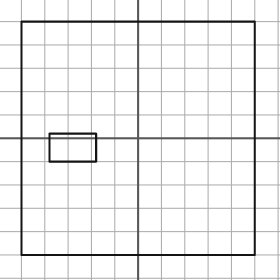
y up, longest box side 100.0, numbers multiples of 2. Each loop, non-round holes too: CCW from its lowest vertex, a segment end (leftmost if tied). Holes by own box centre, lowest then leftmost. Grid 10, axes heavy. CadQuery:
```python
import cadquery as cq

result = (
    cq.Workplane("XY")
    .moveTo(-50.0, -50.0)
    .lineTo(50.0, -50.0)
    .lineTo(50.0, 50.0)
    .lineTo(-50.0, 50.0)
    .close()
    .moveTo(-38.0, -10.0)
    .lineTo(-18.0, -10.0)
    .lineTo(-18.0, 2.0)
    .lineTo(-38.0, 2.0)
    .close()
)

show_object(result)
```